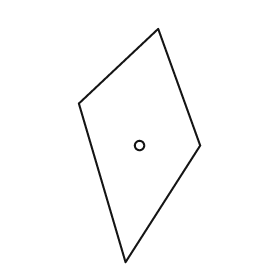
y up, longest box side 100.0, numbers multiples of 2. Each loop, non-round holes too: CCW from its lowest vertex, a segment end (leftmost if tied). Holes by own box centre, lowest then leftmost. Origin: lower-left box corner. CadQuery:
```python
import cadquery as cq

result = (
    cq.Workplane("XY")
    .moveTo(20.0, 0.0)
    .lineTo(52.0, 50.0)
    .lineTo(34.0, 100.0)
    .lineTo(0.0, 68.0)
    .close()
    .moveTo(26.0, 50.0)
    .circle(2.0)
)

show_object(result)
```